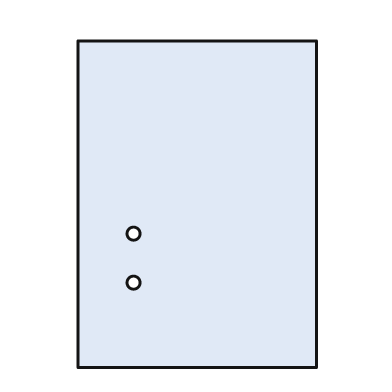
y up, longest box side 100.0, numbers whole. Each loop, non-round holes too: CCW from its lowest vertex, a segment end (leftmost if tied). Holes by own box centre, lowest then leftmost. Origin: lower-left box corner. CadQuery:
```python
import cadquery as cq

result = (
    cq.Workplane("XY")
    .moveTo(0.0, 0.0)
    .lineTo(73.0, 0.0)
    .lineTo(73.0, 100.0)
    .lineTo(0.0, 100.0)
    .close()
    .moveTo(17.0, 26.0)
    .circle(2.0)
    .moveTo(17.0, 41.0)
    .circle(2.0)
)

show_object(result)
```